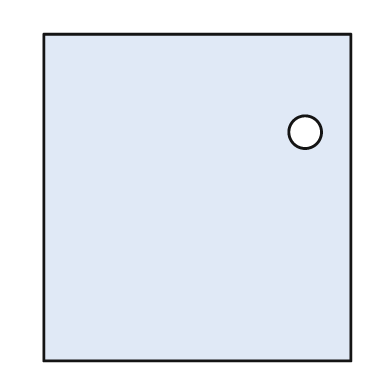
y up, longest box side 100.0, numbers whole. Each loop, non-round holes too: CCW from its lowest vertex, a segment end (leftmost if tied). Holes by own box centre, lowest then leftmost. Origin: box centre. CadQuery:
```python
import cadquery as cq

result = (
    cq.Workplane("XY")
    .moveTo(-47.0, -50.0)
    .lineTo(47.0, -50.0)
    .lineTo(47.0, 50.0)
    .lineTo(-47.0, 50.0)
    .close()
    .moveTo(33.0, 20.0)
    .circle(5.0)
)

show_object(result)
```